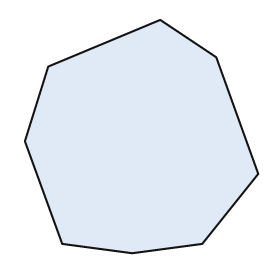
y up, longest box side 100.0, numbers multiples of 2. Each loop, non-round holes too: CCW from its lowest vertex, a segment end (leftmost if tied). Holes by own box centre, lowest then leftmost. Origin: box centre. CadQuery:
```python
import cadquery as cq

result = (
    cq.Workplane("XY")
    .moveTo(-4.0, -50.0)
    .lineTo(26.0, -46.0)
    .lineTo(50.0, -16.0)
    .lineTo(32.0, 34.0)
    .lineTo(8.0, 50.0)
    .lineTo(-40.0, 30.0)
    .lineTo(-50.0, -2.0)
    .lineTo(-34.0, -46.0)
    .close()
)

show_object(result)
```